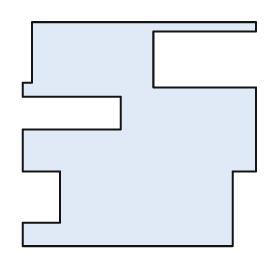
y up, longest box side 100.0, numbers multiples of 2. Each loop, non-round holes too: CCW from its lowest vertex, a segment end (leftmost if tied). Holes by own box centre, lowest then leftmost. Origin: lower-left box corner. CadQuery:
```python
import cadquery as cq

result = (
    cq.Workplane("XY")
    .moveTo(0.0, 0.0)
    .lineTo(90.0, 0.0)
    .lineTo(90.0, 32.0)
    .lineTo(100.0, 32.0)
    .lineTo(100.0, 68.0)
    .lineTo(56.0, 68.0)
    .lineTo(56.0, 92.0)
    .lineTo(100.0, 92.0)
    .lineTo(100.0, 96.0)
    .lineTo(4.0, 96.0)
    .lineTo(4.0, 70.0)
    .lineTo(0.0, 70.0)
    .lineTo(0.0, 64.0)
    .lineTo(42.0, 64.0)
    .lineTo(42.0, 50.0)
    .lineTo(0.0, 50.0)
    .lineTo(0.0, 32.0)
    .lineTo(16.0, 32.0)
    .lineTo(16.0, 10.0)
    .lineTo(0.0, 10.0)
    .close()
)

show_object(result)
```